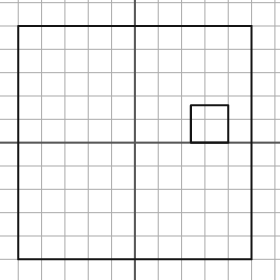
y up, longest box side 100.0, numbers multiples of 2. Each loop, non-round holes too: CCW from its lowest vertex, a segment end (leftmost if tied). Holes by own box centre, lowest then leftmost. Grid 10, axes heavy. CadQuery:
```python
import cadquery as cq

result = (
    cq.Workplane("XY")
    .moveTo(-50.0, -50.0)
    .lineTo(50.0, -50.0)
    .lineTo(50.0, 50.0)
    .lineTo(-50.0, 50.0)
    .close()
    .moveTo(24.0, 0.0)
    .lineTo(40.0, 0.0)
    .lineTo(40.0, 16.0)
    .lineTo(24.0, 16.0)
    .close()
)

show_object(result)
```